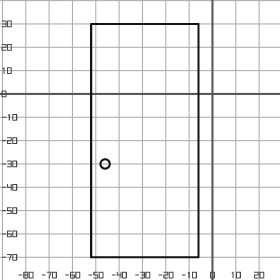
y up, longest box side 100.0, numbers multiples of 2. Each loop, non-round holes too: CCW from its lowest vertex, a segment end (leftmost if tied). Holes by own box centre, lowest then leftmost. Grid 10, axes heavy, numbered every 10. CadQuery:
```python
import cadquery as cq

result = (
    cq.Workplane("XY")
    .moveTo(-52.0, -70.0)
    .lineTo(-6.0, -70.0)
    .lineTo(-6.0, 30.0)
    .lineTo(-52.0, 30.0)
    .close()
    .moveTo(-46.0, -30.0)
    .circle(2.0)
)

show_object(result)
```